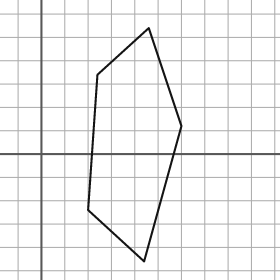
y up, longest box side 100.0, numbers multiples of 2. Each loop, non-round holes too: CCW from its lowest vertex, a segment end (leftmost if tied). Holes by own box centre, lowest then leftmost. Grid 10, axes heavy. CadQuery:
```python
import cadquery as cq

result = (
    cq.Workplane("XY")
    .moveTo(44.0, -46.0)
    .lineTo(60.0, 12.0)
    .lineTo(46.0, 54.0)
    .lineTo(24.0, 34.0)
    .lineTo(20.0, -24.0)
    .close()
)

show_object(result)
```